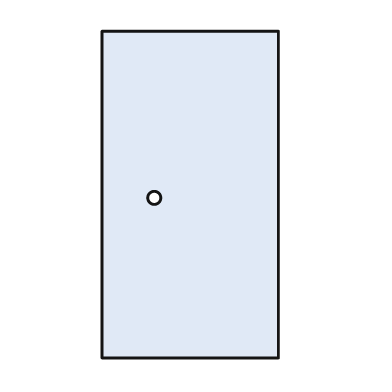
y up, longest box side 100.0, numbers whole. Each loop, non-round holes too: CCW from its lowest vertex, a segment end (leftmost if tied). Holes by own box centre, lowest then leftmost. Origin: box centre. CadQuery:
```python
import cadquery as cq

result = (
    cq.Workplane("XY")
    .moveTo(-27.0, -50.0)
    .lineTo(27.0, -50.0)
    .lineTo(27.0, 50.0)
    .lineTo(-27.0, 50.0)
    .close()
    .moveTo(-11.0, -1.0)
    .circle(2.0)
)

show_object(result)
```